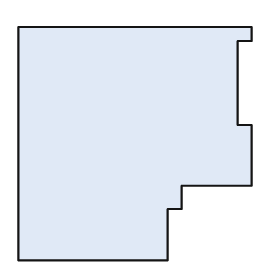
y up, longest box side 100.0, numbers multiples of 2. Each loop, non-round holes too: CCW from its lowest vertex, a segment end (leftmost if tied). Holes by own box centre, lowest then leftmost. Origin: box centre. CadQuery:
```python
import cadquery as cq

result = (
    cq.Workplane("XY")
    .moveTo(-50.0, -50.0)
    .lineTo(14.0, -50.0)
    .lineTo(14.0, -28.0)
    .lineTo(20.0, -28.0)
    .lineTo(20.0, -18.0)
    .lineTo(50.0, -18.0)
    .lineTo(50.0, 8.0)
    .lineTo(44.0, 8.0)
    .lineTo(44.0, 44.0)
    .lineTo(50.0, 44.0)
    .lineTo(50.0, 50.0)
    .lineTo(-50.0, 50.0)
    .close()
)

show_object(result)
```